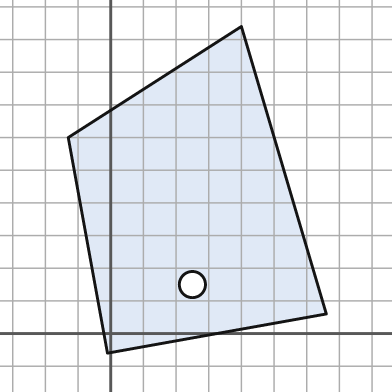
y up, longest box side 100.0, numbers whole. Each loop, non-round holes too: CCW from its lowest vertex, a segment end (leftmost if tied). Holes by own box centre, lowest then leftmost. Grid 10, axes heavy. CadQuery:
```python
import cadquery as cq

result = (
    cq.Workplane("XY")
    .moveTo(-1.0, -6.0)
    .lineTo(66.0, 6.0)
    .lineTo(40.0, 94.0)
    .lineTo(-13.0, 60.0)
    .close()
    .moveTo(25.0, 15.0)
    .circle(4.0)
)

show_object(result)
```